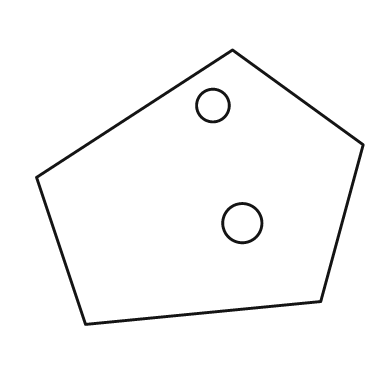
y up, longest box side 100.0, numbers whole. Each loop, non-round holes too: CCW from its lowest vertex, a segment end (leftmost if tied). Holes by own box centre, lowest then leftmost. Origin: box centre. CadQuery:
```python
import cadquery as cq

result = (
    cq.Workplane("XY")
    .moveTo(-35.0, -42.0)
    .lineTo(37.0, -35.0)
    .lineTo(50.0, 13.0)
    .lineTo(10.0, 42.0)
    .lineTo(-50.0, 3.0)
    .close()
    .moveTo(13.0, -11.0)
    .circle(6.0)
    .moveTo(4.0, 25.0)
    .circle(5.0)
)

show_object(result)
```